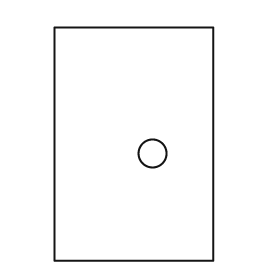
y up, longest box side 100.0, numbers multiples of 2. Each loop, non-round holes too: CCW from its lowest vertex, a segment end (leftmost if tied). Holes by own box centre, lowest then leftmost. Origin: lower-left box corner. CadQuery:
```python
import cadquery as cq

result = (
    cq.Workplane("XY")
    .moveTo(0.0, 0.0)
    .lineTo(68.0, 0.0)
    .lineTo(68.0, 100.0)
    .lineTo(0.0, 100.0)
    .close()
    .moveTo(42.0, 46.0)
    .circle(6.0)
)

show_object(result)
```